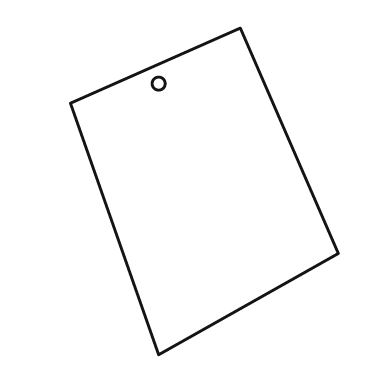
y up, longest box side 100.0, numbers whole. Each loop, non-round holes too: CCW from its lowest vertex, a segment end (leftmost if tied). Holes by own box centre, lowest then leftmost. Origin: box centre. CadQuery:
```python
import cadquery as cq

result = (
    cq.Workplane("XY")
    .moveTo(-14.0, -50.0)
    .lineTo(41.0, -19.0)
    .lineTo(11.0, 50.0)
    .lineTo(-41.0, 27.0)
    .close()
    .moveTo(-14.0, 33.0)
    .circle(2.0)
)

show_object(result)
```